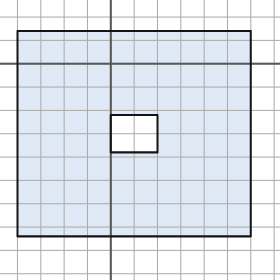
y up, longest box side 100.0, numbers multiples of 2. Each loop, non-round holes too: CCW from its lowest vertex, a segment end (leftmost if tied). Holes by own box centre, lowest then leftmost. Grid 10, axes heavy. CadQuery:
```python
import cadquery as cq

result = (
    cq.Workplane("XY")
    .moveTo(-40.0, -74.0)
    .lineTo(60.0, -74.0)
    .lineTo(60.0, 14.0)
    .lineTo(-40.0, 14.0)
    .close()
    .moveTo(0.0, -38.0)
    .lineTo(20.0, -38.0)
    .lineTo(20.0, -22.0)
    .lineTo(0.0, -22.0)
    .close()
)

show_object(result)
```